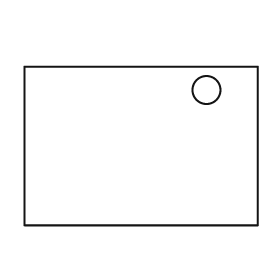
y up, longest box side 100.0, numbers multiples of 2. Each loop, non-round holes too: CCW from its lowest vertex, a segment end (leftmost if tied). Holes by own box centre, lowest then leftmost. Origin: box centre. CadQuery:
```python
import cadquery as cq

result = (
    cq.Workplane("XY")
    .moveTo(-50.0, -34.0)
    .lineTo(50.0, -34.0)
    .lineTo(50.0, 34.0)
    .lineTo(-50.0, 34.0)
    .close()
    .moveTo(28.0, 24.0)
    .circle(6.0)
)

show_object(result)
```